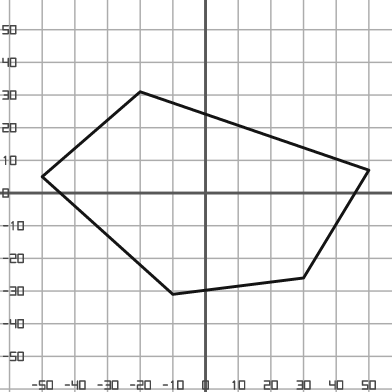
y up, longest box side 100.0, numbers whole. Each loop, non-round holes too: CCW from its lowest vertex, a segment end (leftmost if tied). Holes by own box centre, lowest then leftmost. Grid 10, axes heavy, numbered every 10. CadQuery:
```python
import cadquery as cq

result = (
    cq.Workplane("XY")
    .moveTo(-10.0, -31.0)
    .lineTo(30.0, -26.0)
    .lineTo(50.0, 7.0)
    .lineTo(-20.0, 31.0)
    .lineTo(-50.0, 5.0)
    .close()
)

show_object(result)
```